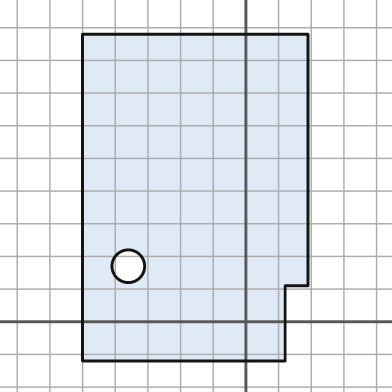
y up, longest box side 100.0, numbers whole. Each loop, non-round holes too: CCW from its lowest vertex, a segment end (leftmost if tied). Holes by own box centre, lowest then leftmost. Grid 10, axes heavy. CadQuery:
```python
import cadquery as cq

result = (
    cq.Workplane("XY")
    .moveTo(-50.0, -12.0)
    .lineTo(12.0, -12.0)
    .lineTo(12.0, 11.0)
    .lineTo(19.0, 11.0)
    .lineTo(19.0, 88.0)
    .lineTo(-50.0, 88.0)
    .close()
    .moveTo(-36.0, 17.0)
    .circle(5.0)
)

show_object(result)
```